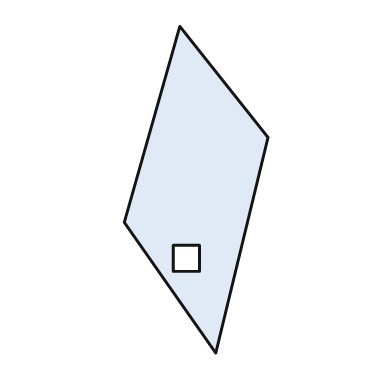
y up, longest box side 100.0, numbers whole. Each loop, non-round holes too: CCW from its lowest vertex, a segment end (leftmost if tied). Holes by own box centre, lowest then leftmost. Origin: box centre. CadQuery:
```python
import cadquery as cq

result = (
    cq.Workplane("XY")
    .moveTo(6.0, -50.0)
    .lineTo(22.0, 16.0)
    .lineTo(-5.0, 50.0)
    .lineTo(-22.0, -10.0)
    .close()
    .moveTo(-7.0, -25.0)
    .lineTo(1.0, -25.0)
    .lineTo(1.0, -17.0)
    .lineTo(-7.0, -17.0)
    .close()
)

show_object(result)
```